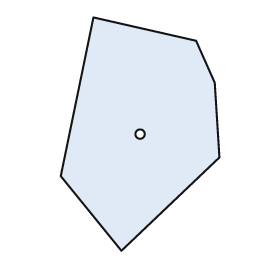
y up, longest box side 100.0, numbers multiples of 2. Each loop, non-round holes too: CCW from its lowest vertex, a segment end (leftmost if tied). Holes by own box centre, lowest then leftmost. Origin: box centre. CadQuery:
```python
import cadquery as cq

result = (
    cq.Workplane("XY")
    .moveTo(-8.0, -50.0)
    .lineTo(34.0, -10.0)
    .lineTo(32.0, 22.0)
    .lineTo(24.0, 40.0)
    .lineTo(-20.0, 50.0)
    .lineTo(-34.0, -18.0)
    .close()
    .moveTo(0.0, 0.0)
    .circle(2.0)
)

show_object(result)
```